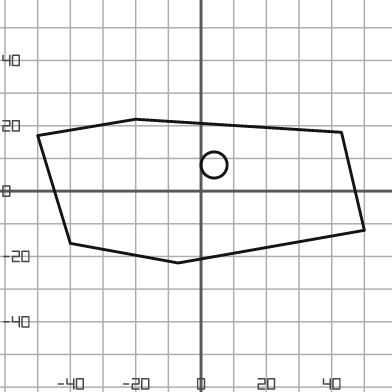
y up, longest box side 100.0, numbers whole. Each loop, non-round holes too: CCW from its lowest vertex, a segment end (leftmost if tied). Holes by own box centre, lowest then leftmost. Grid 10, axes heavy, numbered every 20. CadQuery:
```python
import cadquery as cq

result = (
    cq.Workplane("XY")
    .moveTo(-7.0, -22.0)
    .lineTo(50.0, -12.0)
    .lineTo(43.0, 18.0)
    .lineTo(-20.0, 22.0)
    .lineTo(-50.0, 17.0)
    .lineTo(-40.0, -16.0)
    .close()
    .moveTo(4.0, 8.0)
    .circle(4.0)
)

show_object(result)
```